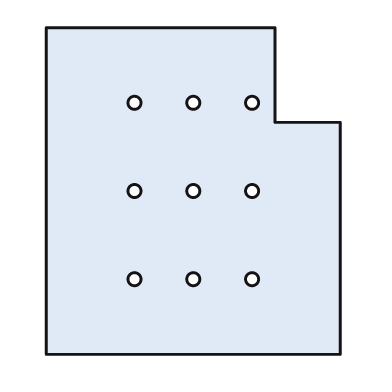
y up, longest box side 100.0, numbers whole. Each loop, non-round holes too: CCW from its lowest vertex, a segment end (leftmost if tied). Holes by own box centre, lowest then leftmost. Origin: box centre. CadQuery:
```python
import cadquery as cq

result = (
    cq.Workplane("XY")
    .moveTo(-45.0, -50.0)
    .lineTo(45.0, -50.0)
    .lineTo(45.0, 21.0)
    .lineTo(25.0, 21.0)
    .lineTo(25.0, 50.0)
    .lineTo(-45.0, 50.0)
    .close()
    .moveTo(-18.0, -27.0)
    .circle(2.0)
    .moveTo(0.0, -27.0)
    .circle(2.0)
    .moveTo(18.0, -27.0)
    .circle(2.0)
    .moveTo(-18.0, 0.0)
    .circle(2.0)
    .moveTo(0.0, 0.0)
    .circle(2.0)
    .moveTo(18.0, 0.0)
    .circle(2.0)
    .moveTo(-18.0, 27.0)
    .circle(2.0)
    .moveTo(0.0, 27.0)
    .circle(2.0)
    .moveTo(18.0, 27.0)
    .circle(2.0)
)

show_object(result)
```